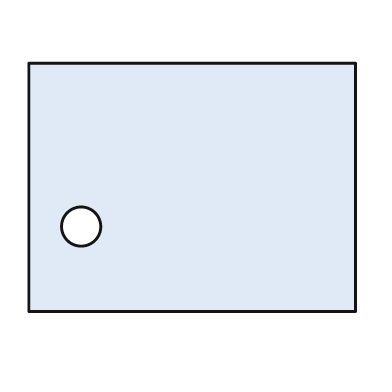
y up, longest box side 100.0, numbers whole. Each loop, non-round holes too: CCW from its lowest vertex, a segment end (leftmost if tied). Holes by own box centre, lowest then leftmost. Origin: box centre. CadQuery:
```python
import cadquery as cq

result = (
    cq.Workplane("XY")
    .moveTo(-50.0, -38.0)
    .lineTo(50.0, -38.0)
    .lineTo(50.0, 38.0)
    .lineTo(-50.0, 38.0)
    .close()
    .moveTo(-34.0, -12.0)
    .circle(6.0)
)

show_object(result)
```